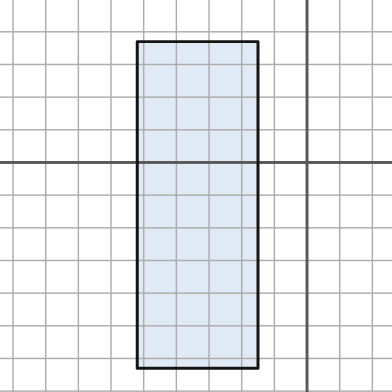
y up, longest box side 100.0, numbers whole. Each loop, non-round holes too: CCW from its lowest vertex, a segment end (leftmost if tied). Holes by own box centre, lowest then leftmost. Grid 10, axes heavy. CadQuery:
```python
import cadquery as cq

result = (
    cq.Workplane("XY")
    .moveTo(-52.0, -63.0)
    .lineTo(-15.0, -63.0)
    .lineTo(-15.0, 37.0)
    .lineTo(-52.0, 37.0)
    .close()
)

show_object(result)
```